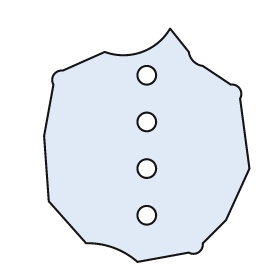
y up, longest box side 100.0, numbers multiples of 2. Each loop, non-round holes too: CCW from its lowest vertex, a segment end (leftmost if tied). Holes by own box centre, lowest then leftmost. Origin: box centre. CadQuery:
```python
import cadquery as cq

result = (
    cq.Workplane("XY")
    .moveTo(-4.0, -50.0)
    .lineTo(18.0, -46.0)
    .threePointArc((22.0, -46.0), (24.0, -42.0))
    .lineTo(34.0, -32.0)
    .lineTo(44.0, -10.0)
    .lineTo(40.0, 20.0)
    .threePointArc((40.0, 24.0), (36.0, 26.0))
    .lineTo(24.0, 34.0)
    .threePointArc((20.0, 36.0), (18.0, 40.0))
    .lineTo(10.0, 50.0)
    .threePointArc((-2.0, 40.0), (-18.0, 40.0))
    .lineTo(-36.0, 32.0)
    .threePointArc((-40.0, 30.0), (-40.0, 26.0))
    .lineTo(-44.0, 4.0)
    .lineTo(-42.0, -24.0)
    .lineTo(-26.0, -42.0)
    .threePointArc((-14.0, -44.0), (-4.0, -50.0))
    .close()
    .moveTo(0.0, -30.0)
    .circle(4.0)
    .moveTo(0.0, -10.0)
    .circle(4.0)
    .moveTo(0.0, 10.0)
    .circle(4.0)
    .moveTo(0.0, 30.0)
    .circle(4.0)
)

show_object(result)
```